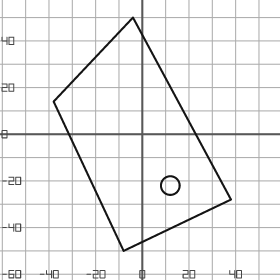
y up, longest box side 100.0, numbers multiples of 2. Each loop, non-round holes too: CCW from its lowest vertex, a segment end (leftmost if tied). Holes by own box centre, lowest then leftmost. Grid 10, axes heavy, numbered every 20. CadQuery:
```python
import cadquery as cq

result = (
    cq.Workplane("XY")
    .moveTo(-8.0, -50.0)
    .lineTo(38.0, -28.0)
    .lineTo(-4.0, 50.0)
    .lineTo(-38.0, 14.0)
    .close()
    .moveTo(12.0, -22.0)
    .circle(4.0)
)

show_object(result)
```